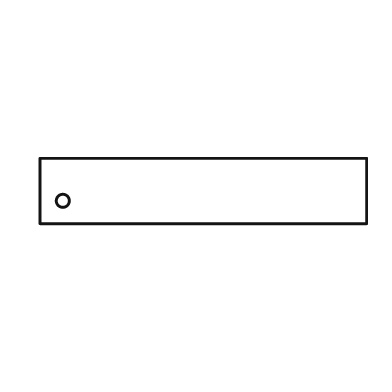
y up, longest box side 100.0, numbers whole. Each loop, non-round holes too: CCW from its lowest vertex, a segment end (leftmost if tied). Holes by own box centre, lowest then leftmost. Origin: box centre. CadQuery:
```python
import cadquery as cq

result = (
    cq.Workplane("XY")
    .moveTo(-50.0, -10.0)
    .lineTo(50.0, -10.0)
    .lineTo(50.0, 10.0)
    .lineTo(-50.0, 10.0)
    .close()
    .moveTo(-43.0, -3.0)
    .circle(2.0)
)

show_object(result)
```